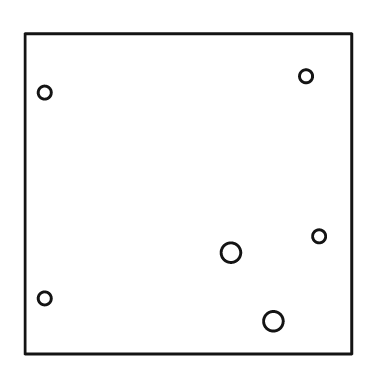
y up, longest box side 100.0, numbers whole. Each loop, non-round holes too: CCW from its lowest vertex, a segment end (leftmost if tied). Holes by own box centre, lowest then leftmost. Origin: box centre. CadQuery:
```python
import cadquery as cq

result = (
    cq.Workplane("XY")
    .moveTo(-50.0, -49.0)
    .lineTo(50.0, -49.0)
    .lineTo(50.0, 49.0)
    .lineTo(-50.0, 49.0)
    .close()
    .moveTo(26.0, -39.0)
    .circle(3.0)
    .moveTo(-44.0, -32.0)
    .circle(2.0)
    .moveTo(13.0, -18.0)
    .circle(3.0)
    .moveTo(40.0, -13.0)
    .circle(2.0)
    .moveTo(-44.0, 31.0)
    .circle(2.0)
    .moveTo(36.0, 36.0)
    .circle(2.0)
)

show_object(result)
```